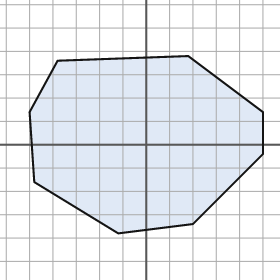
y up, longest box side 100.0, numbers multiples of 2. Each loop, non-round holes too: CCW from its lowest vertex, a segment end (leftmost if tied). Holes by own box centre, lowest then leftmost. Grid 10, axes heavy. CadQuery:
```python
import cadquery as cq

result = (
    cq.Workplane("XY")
    .moveTo(-12.0, -38.0)
    .lineTo(20.0, -34.0)
    .lineTo(50.0, -4.0)
    .lineTo(50.0, 14.0)
    .lineTo(18.0, 38.0)
    .lineTo(-38.0, 36.0)
    .lineTo(-50.0, 14.0)
    .lineTo(-48.0, -16.0)
    .close()
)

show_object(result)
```